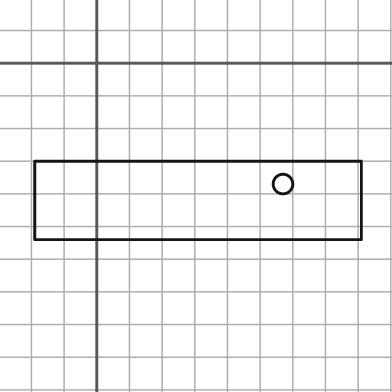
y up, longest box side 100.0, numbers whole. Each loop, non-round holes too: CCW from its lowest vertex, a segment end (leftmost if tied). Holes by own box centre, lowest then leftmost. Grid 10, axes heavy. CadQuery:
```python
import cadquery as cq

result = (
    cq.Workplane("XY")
    .moveTo(-19.0, -54.0)
    .lineTo(81.0, -54.0)
    .lineTo(81.0, -30.0)
    .lineTo(-19.0, -30.0)
    .close()
    .moveTo(57.0, -37.0)
    .circle(3.0)
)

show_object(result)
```